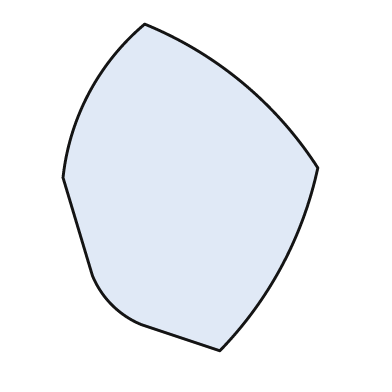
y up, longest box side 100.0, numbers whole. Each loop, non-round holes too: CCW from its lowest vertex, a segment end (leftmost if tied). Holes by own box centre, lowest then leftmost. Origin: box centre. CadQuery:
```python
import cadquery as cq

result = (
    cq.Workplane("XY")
    .moveTo(9.0, -50.0)
    .threePointArc((28.0, -24.0), (39.0, 6.0))
    .threePointArc((16.0, 32.0), (-14.0, 50.0))
    .threePointArc((-31.0, 29.0), (-39.0, 3.0))
    .lineTo(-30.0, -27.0)
    .threePointArc((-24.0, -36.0), (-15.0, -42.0))
    .close()
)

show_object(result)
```